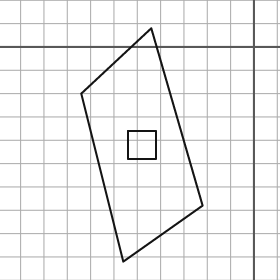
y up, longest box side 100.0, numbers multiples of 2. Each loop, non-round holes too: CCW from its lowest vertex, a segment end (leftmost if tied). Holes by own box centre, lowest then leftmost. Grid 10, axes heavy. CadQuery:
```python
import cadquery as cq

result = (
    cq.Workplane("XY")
    .moveTo(-56.0, -92.0)
    .lineTo(-22.0, -68.0)
    .lineTo(-44.0, 8.0)
    .lineTo(-74.0, -20.0)
    .close()
    .moveTo(-54.0, -48.0)
    .lineTo(-42.0, -48.0)
    .lineTo(-42.0, -36.0)
    .lineTo(-54.0, -36.0)
    .close()
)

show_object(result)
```